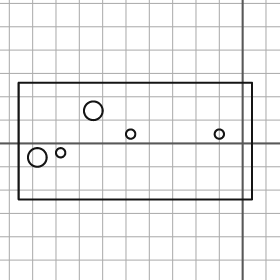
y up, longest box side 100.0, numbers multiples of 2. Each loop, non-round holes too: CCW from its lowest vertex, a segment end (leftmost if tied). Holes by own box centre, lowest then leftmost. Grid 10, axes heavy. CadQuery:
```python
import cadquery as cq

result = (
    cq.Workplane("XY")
    .moveTo(-96.0, -24.0)
    .lineTo(4.0, -24.0)
    .lineTo(4.0, 26.0)
    .lineTo(-96.0, 26.0)
    .close()
    .moveTo(-88.0, -6.0)
    .circle(4.0)
    .moveTo(-78.0, -4.0)
    .circle(2.0)
    .moveTo(-48.0, 4.0)
    .circle(2.0)
    .moveTo(-10.0, 4.0)
    .circle(2.0)
    .moveTo(-64.0, 14.0)
    .circle(4.0)
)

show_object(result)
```